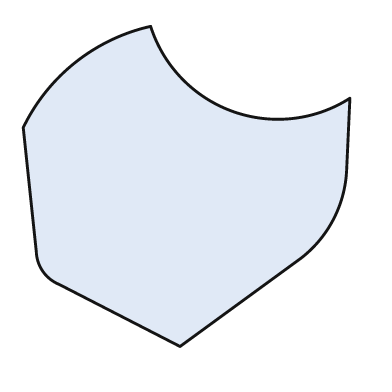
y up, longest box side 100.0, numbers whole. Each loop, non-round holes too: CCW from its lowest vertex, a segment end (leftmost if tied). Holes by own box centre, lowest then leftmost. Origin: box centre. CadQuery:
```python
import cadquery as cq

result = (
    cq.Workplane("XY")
    .moveTo(-2.0, -49.0)
    .lineTo(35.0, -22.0)
    .threePointArc((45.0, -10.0), (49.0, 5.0))
    .lineTo(50.0, 27.0)
    .threePointArc((14.0, 23.0), (-11.0, 49.0))
    .threePointArc((-34.0, 38.0), (-50.0, 18.0))
    .lineTo(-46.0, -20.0)
    .threePointArc((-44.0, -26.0), (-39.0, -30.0))
    .close()
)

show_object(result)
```